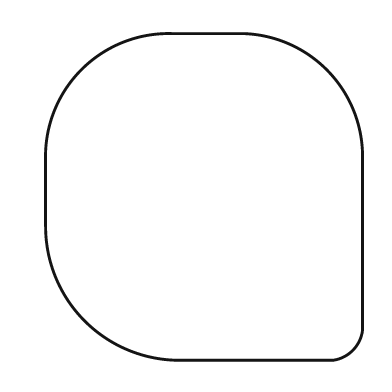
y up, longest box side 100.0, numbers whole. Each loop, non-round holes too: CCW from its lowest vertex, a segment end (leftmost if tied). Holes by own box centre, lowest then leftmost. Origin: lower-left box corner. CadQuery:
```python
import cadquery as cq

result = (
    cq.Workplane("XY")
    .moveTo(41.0, 0.0)
    .lineTo(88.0, 0.0)
    .threePointArc((94.0, 3.0), (97.0, 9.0))
    .lineTo(97.0, 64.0)
    .threePointArc((86.0, 89.0), (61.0, 100.0))
    .lineTo(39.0, 100.0)
    .threePointArc((11.0, 89.0), (0.0, 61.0))
    .lineTo(0.0, 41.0)
    .threePointArc((12.0, 12.0), (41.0, 0.0))
    .close()
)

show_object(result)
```